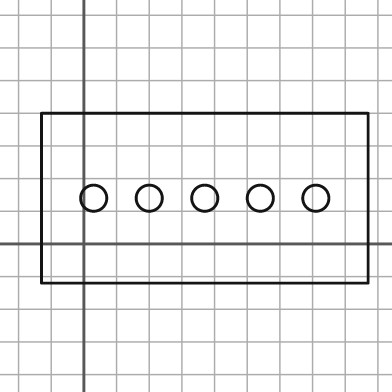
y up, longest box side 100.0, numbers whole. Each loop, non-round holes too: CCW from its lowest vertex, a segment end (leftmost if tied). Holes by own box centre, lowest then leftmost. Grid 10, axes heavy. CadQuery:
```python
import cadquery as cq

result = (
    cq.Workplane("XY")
    .moveTo(-13.0, -12.0)
    .lineTo(87.0, -12.0)
    .lineTo(87.0, 40.0)
    .lineTo(-13.0, 40.0)
    .close()
    .moveTo(3.0, 14.0)
    .circle(4.0)
    .moveTo(20.0, 14.0)
    .circle(4.0)
    .moveTo(37.0, 14.0)
    .circle(4.0)
    .moveTo(54.0, 14.0)
    .circle(4.0)
    .moveTo(71.0, 14.0)
    .circle(4.0)
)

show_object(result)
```